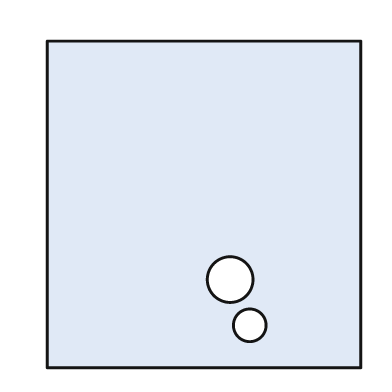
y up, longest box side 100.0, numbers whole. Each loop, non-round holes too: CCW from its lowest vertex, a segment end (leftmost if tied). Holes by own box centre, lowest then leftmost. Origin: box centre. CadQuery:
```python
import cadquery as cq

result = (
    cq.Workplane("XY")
    .moveTo(-48.0, -50.0)
    .lineTo(48.0, -50.0)
    .lineTo(48.0, 50.0)
    .lineTo(-48.0, 50.0)
    .close()
    .moveTo(14.0, -37.0)
    .circle(5.0)
    .moveTo(8.0, -23.0)
    .circle(7.0)
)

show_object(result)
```